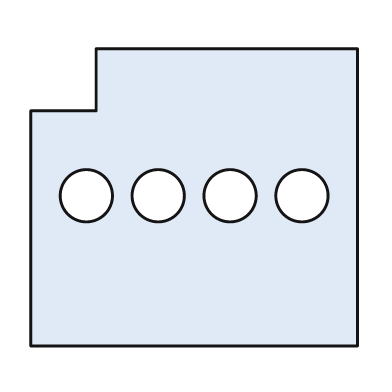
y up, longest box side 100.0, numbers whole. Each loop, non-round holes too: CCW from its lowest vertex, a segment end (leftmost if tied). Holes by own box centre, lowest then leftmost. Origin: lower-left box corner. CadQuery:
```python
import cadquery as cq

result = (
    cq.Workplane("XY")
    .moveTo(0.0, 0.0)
    .lineTo(100.0, 0.0)
    .lineTo(100.0, 91.0)
    .lineTo(20.0, 91.0)
    .lineTo(20.0, 72.0)
    .lineTo(0.0, 72.0)
    .close()
    .moveTo(17.0, 46.0)
    .circle(8.0)
    .moveTo(39.0, 46.0)
    .circle(8.0)
    .moveTo(61.0, 46.0)
    .circle(8.0)
    .moveTo(83.0, 46.0)
    .circle(8.0)
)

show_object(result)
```